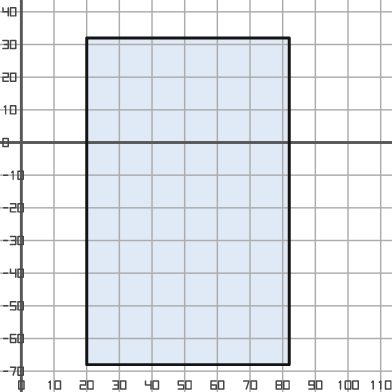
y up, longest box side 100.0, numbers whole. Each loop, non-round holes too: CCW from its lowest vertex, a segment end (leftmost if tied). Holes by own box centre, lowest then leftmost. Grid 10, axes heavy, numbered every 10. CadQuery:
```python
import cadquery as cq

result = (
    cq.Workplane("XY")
    .moveTo(20.0, -68.0)
    .lineTo(82.0, -68.0)
    .lineTo(82.0, 32.0)
    .lineTo(20.0, 32.0)
    .close()
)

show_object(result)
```